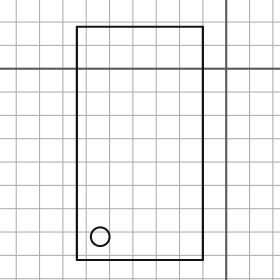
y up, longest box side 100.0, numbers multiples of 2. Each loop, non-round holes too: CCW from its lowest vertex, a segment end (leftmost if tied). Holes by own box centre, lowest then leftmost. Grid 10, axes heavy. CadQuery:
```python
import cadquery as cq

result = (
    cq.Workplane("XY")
    .moveTo(-64.0, -82.0)
    .lineTo(-10.0, -82.0)
    .lineTo(-10.0, 18.0)
    .lineTo(-64.0, 18.0)
    .close()
    .moveTo(-54.0, -72.0)
    .circle(4.0)
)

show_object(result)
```